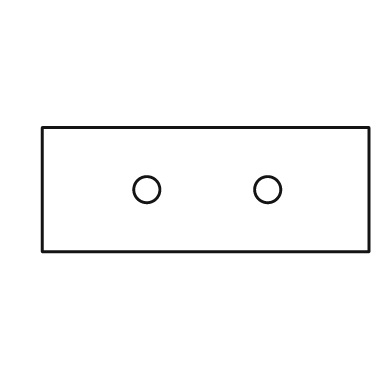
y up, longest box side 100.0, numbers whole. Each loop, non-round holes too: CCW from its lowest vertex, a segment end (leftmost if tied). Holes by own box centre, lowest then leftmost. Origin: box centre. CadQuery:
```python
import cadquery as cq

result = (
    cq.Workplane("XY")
    .moveTo(-50.0, -19.0)
    .lineTo(50.0, -19.0)
    .lineTo(50.0, 19.0)
    .lineTo(-50.0, 19.0)
    .close()
    .moveTo(-18.0, 0.0)
    .circle(4.0)
    .moveTo(19.0, 0.0)
    .circle(4.0)
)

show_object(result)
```